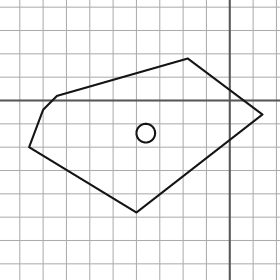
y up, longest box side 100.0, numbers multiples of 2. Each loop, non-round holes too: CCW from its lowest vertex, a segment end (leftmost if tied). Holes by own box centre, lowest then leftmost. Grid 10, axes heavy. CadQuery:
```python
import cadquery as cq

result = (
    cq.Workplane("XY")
    .moveTo(-40.0, -48.0)
    .lineTo(14.0, -6.0)
    .lineTo(-18.0, 18.0)
    .lineTo(-74.0, 2.0)
    .lineTo(-80.0, -4.0)
    .lineTo(-86.0, -20.0)
    .close()
    .moveTo(-36.0, -14.0)
    .circle(4.0)
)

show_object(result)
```